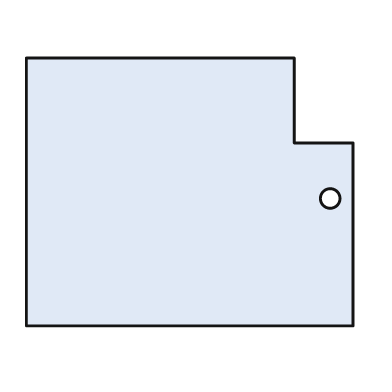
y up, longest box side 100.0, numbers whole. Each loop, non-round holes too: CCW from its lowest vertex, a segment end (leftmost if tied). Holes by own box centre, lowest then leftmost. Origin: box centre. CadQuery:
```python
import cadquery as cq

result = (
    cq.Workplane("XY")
    .moveTo(-50.0, -41.0)
    .lineTo(50.0, -41.0)
    .lineTo(50.0, 15.0)
    .lineTo(32.0, 15.0)
    .lineTo(32.0, 41.0)
    .lineTo(-50.0, 41.0)
    .close()
    .moveTo(43.0, -2.0)
    .circle(3.0)
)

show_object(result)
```